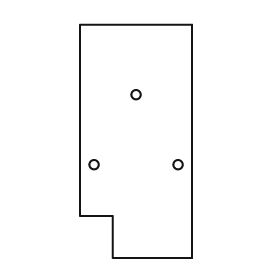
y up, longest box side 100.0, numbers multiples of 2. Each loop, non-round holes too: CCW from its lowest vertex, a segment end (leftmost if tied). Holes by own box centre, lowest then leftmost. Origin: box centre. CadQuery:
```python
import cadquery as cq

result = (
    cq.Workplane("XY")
    .moveTo(-10.0, -50.0)
    .lineTo(24.0, -50.0)
    .lineTo(24.0, 50.0)
    .lineTo(-24.0, 50.0)
    .lineTo(-24.0, -32.0)
    .lineTo(-10.0, -32.0)
    .close()
    .moveTo(-18.0, -10.0)
    .circle(2.0)
    .moveTo(18.0, -10.0)
    .circle(2.0)
    .moveTo(0.0, 20.0)
    .circle(2.0)
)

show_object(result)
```